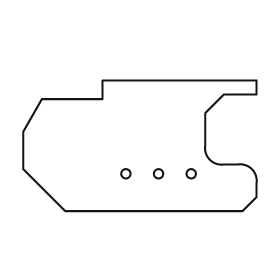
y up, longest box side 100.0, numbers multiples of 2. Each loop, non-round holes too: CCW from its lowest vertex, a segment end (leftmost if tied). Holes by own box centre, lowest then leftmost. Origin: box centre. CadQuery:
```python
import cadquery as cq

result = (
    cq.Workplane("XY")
    .moveTo(-32.0, -28.0)
    .lineTo(44.0, -28.0)
    .lineTo(50.0, -22.0)
    .lineTo(50.0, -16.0)
    .threePointArc((48.0, -10.0), (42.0, -8.0))
    .lineTo(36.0, -8.0)
    .threePointArc((30.0, -6.0), (28.0, 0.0))
    .lineTo(28.0, 14.0)
    .lineTo(36.0, 22.0)
    .lineTo(50.0, 22.0)
    .lineTo(50.0, 28.0)
    .lineTo(-16.0, 28.0)
    .lineTo(-16.0, 20.0)
    .lineTo(-42.0, 20.0)
    .lineTo(-50.0, 6.0)
    .lineTo(-50.0, -10.0)
    .close()
    .moveTo(-6.0, -12.0)
    .circle(2.0)
    .moveTo(8.0, -12.0)
    .circle(2.0)
    .moveTo(22.0, -12.0)
    .circle(2.0)
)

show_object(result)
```